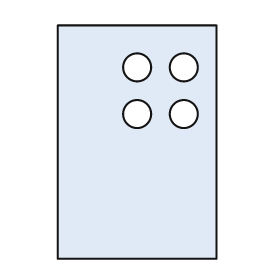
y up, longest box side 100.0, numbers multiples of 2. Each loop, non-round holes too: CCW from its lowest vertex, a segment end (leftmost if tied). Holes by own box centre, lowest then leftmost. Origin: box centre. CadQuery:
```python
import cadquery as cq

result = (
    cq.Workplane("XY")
    .moveTo(-34.0, -50.0)
    .lineTo(34.0, -50.0)
    .lineTo(34.0, 50.0)
    .lineTo(-34.0, 50.0)
    .close()
    .moveTo(0.0, 12.0)
    .circle(6.0)
    .moveTo(20.0, 12.0)
    .circle(6.0)
    .moveTo(0.0, 32.0)
    .circle(6.0)
    .moveTo(20.0, 32.0)
    .circle(6.0)
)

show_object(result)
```